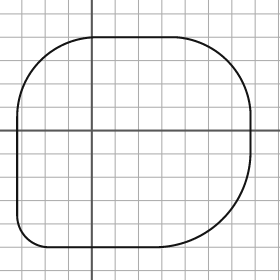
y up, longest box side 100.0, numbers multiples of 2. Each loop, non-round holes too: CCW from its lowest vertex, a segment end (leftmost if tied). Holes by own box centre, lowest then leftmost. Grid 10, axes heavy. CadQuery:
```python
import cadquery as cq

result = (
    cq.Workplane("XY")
    .moveTo(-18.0, -50.0)
    .lineTo(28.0, -50.0)
    .threePointArc((56.0, -38.0), (68.0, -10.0))
    .lineTo(68.0, 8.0)
    .threePointArc((58.0, 30.0), (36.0, 40.0))
    .lineTo(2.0, 40.0)
    .threePointArc((-22.0, 30.0), (-32.0, 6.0))
    .lineTo(-32.0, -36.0)
    .threePointArc((-28.0, -46.0), (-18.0, -50.0))
    .close()
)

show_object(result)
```